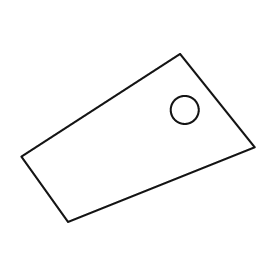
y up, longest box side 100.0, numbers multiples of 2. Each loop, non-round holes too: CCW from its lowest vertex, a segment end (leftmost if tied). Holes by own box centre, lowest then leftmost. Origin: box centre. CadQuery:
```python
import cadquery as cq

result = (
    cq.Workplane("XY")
    .moveTo(-30.0, -36.0)
    .lineTo(50.0, -4.0)
    .lineTo(18.0, 36.0)
    .lineTo(-50.0, -8.0)
    .close()
    .moveTo(20.0, 12.0)
    .circle(6.0)
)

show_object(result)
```